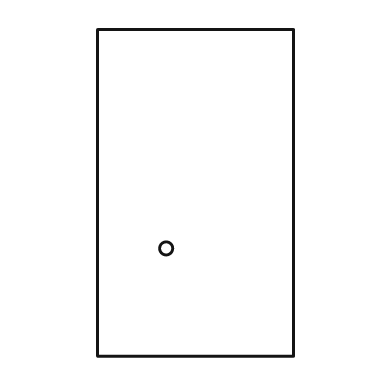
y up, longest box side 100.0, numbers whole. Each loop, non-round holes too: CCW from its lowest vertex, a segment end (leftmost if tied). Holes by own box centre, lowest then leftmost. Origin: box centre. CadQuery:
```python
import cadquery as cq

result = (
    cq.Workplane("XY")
    .moveTo(-30.0, -50.0)
    .lineTo(30.0, -50.0)
    .lineTo(30.0, 50.0)
    .lineTo(-30.0, 50.0)
    .close()
    .moveTo(-9.0, -17.0)
    .circle(2.0)
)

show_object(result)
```